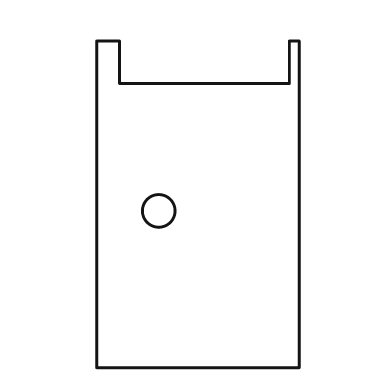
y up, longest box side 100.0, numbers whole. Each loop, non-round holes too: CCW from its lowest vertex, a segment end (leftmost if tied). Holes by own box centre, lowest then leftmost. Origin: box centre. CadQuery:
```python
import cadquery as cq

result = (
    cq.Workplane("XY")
    .moveTo(-31.0, -50.0)
    .lineTo(31.0, -50.0)
    .lineTo(31.0, 50.0)
    .lineTo(28.0, 50.0)
    .lineTo(28.0, 37.0)
    .lineTo(-24.0, 37.0)
    .lineTo(-24.0, 50.0)
    .lineTo(-31.0, 50.0)
    .close()
    .moveTo(-12.0, -2.0)
    .circle(5.0)
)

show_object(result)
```